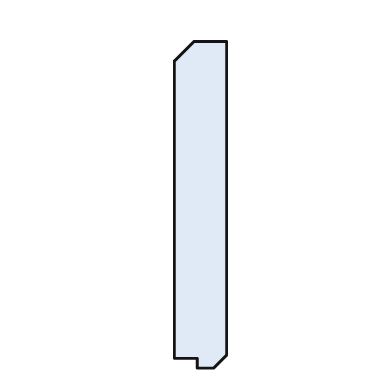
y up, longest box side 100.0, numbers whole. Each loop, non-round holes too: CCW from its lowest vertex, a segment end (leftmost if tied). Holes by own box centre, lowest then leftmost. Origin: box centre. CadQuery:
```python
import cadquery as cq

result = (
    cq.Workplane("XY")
    .moveTo(-1.0, -50.0)
    .lineTo(4.0, -50.0)
    .lineTo(8.0, -46.0)
    .lineTo(8.0, 50.0)
    .lineTo(-2.0, 50.0)
    .lineTo(-8.0, 44.0)
    .lineTo(-8.0, -47.0)
    .lineTo(-1.0, -47.0)
    .close()
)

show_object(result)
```